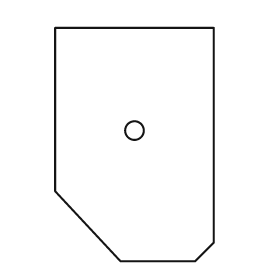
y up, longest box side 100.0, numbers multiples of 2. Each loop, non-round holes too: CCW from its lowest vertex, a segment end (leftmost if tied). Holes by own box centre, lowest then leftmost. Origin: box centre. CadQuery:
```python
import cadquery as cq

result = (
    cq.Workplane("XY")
    .moveTo(-6.0, -50.0)
    .lineTo(26.0, -50.0)
    .lineTo(34.0, -42.0)
    .lineTo(34.0, 50.0)
    .lineTo(-34.0, 50.0)
    .lineTo(-34.0, -20.0)
    .close()
    .moveTo(0.0, 6.0)
    .circle(4.0)
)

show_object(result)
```